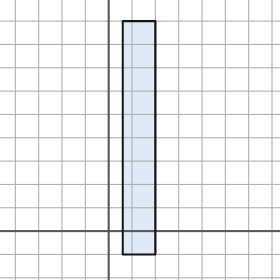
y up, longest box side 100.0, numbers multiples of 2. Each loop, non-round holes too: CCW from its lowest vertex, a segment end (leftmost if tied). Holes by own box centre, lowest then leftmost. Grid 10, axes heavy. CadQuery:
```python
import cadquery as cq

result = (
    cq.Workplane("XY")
    .moveTo(6.0, -10.0)
    .lineTo(20.0, -10.0)
    .lineTo(20.0, 90.0)
    .lineTo(6.0, 90.0)
    .close()
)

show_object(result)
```